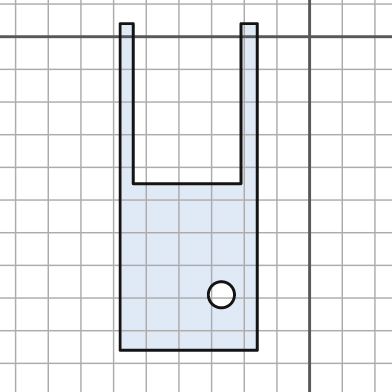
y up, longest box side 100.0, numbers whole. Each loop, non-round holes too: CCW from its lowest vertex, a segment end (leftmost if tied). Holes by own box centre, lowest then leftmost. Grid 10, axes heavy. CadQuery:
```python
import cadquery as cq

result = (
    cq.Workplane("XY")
    .moveTo(-58.0, -96.0)
    .lineTo(-16.0, -96.0)
    .lineTo(-16.0, 4.0)
    .lineTo(-21.0, 4.0)
    .lineTo(-21.0, -45.0)
    .lineTo(-54.0, -45.0)
    .lineTo(-54.0, 4.0)
    .lineTo(-58.0, 4.0)
    .close()
    .moveTo(-27.0, -79.0)
    .circle(4.0)
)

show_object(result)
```